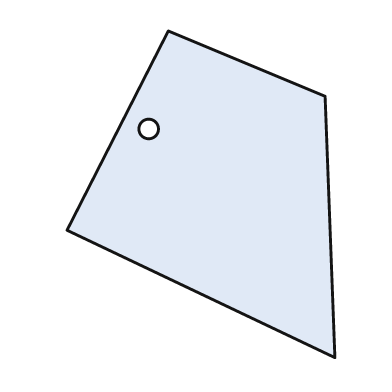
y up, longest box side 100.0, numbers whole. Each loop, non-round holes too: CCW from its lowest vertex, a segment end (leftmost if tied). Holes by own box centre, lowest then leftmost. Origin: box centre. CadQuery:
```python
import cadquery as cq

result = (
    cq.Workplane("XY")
    .moveTo(41.0, -50.0)
    .lineTo(38.0, 30.0)
    .lineTo(-10.0, 50.0)
    .lineTo(-41.0, -11.0)
    .close()
    .moveTo(-16.0, 20.0)
    .circle(3.0)
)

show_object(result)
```